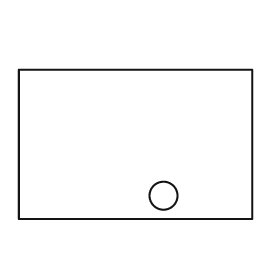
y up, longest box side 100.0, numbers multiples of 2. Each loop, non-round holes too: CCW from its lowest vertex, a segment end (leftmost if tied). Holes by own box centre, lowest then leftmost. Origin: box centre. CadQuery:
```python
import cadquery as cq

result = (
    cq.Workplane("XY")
    .moveTo(-50.0, -32.0)
    .lineTo(50.0, -32.0)
    .lineTo(50.0, 32.0)
    .lineTo(-50.0, 32.0)
    .close()
    .moveTo(12.0, -22.0)
    .circle(6.0)
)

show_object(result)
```